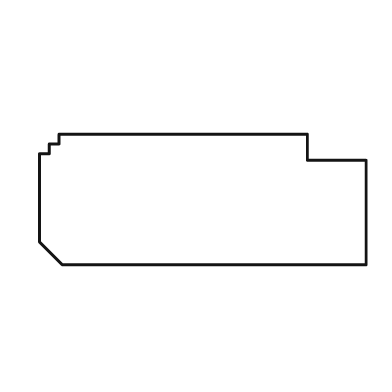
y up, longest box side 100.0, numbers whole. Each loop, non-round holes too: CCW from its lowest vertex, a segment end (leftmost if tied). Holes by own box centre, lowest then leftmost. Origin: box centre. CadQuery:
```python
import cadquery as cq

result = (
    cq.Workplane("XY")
    .moveTo(-43.0, -20.0)
    .lineTo(50.0, -20.0)
    .lineTo(50.0, 12.0)
    .lineTo(32.0, 12.0)
    .lineTo(32.0, 20.0)
    .lineTo(-44.0, 20.0)
    .lineTo(-44.0, 17.0)
    .lineTo(-47.0, 17.0)
    .lineTo(-47.0, 14.0)
    .lineTo(-50.0, 14.0)
    .lineTo(-50.0, -13.0)
    .close()
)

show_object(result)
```